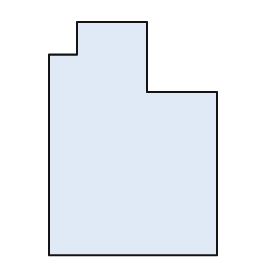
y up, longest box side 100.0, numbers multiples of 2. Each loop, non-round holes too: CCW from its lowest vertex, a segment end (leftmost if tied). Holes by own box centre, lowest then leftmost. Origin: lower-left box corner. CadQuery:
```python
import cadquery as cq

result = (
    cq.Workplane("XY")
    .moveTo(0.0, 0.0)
    .lineTo(72.0, 0.0)
    .lineTo(72.0, 70.0)
    .lineTo(42.0, 70.0)
    .lineTo(42.0, 100.0)
    .lineTo(12.0, 100.0)
    .lineTo(12.0, 86.0)
    .lineTo(0.0, 86.0)
    .close()
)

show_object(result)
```